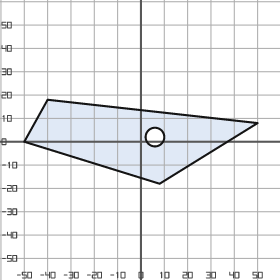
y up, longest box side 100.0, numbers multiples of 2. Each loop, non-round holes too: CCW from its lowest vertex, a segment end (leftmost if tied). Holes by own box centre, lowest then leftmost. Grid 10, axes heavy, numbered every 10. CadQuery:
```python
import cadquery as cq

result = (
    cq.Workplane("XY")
    .moveTo(8.0, -18.0)
    .lineTo(50.0, 8.0)
    .lineTo(-40.0, 18.0)
    .lineTo(-50.0, 0.0)
    .close()
    .moveTo(6.0, 2.0)
    .circle(4.0)
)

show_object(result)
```